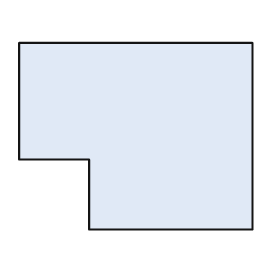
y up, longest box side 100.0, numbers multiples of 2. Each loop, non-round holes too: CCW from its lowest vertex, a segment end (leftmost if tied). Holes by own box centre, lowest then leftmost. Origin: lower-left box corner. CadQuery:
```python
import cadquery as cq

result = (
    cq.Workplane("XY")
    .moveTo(30.0, 0.0)
    .lineTo(100.0, 0.0)
    .lineTo(100.0, 80.0)
    .lineTo(0.0, 80.0)
    .lineTo(0.0, 30.0)
    .lineTo(30.0, 30.0)
    .close()
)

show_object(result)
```